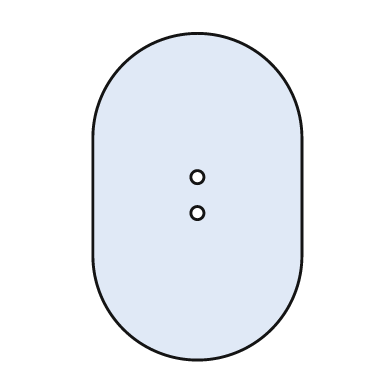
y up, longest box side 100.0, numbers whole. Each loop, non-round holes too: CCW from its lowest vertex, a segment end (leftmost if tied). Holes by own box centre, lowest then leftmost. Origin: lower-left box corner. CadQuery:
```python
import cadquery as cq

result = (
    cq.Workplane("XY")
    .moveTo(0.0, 32.0)
    .threePointArc((32.0, 0.0), (64.0, 32.0))
    .lineTo(64.0, 68.0)
    .threePointArc((32.0, 100.0), (0.0, 68.0))
    .close()
    .moveTo(32.0, 45.0)
    .circle(2.0)
    .moveTo(32.0, 56.0)
    .circle(2.0)
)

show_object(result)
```